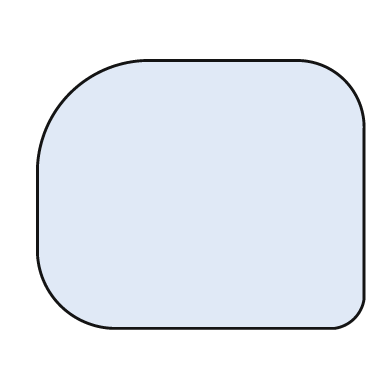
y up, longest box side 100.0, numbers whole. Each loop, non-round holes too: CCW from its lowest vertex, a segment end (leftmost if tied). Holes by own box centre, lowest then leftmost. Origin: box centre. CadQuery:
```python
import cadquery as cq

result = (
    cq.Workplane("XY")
    .moveTo(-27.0, -41.0)
    .lineTo(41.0, -41.0)
    .threePointArc((47.0, -38.0), (50.0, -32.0))
    .lineTo(50.0, 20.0)
    .threePointArc((44.0, 35.0), (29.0, 41.0))
    .lineTo(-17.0, 41.0)
    .threePointArc((-40.0, 31.0), (-50.0, 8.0))
    .lineTo(-50.0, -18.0)
    .threePointArc((-43.0, -34.0), (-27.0, -41.0))
    .close()
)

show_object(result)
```